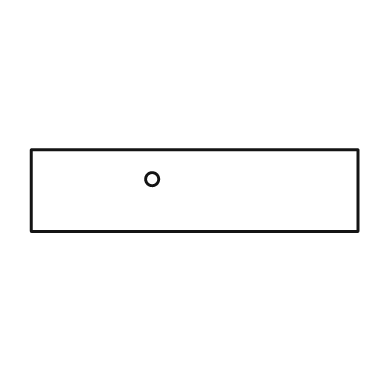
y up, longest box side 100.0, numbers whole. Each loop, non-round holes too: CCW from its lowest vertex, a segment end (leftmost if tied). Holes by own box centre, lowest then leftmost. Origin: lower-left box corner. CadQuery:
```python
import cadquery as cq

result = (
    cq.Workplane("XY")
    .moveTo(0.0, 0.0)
    .lineTo(100.0, 0.0)
    .lineTo(100.0, 25.0)
    .lineTo(0.0, 25.0)
    .close()
    .moveTo(37.0, 16.0)
    .circle(2.0)
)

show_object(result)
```